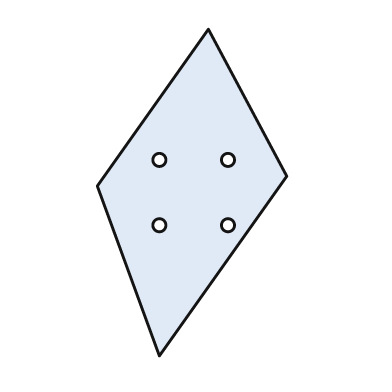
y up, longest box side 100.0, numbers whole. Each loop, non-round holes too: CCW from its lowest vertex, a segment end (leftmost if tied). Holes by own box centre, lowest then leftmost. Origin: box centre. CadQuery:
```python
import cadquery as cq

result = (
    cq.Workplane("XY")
    .moveTo(-10.0, -50.0)
    .lineTo(29.0, 5.0)
    .lineTo(5.0, 50.0)
    .lineTo(-29.0, 2.0)
    .close()
    .moveTo(-10.0, -10.0)
    .circle(2.0)
    .moveTo(11.0, -10.0)
    .circle(2.0)
    .moveTo(-10.0, 10.0)
    .circle(2.0)
    .moveTo(11.0, 10.0)
    .circle(2.0)
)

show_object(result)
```